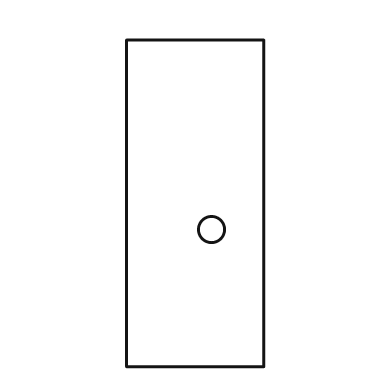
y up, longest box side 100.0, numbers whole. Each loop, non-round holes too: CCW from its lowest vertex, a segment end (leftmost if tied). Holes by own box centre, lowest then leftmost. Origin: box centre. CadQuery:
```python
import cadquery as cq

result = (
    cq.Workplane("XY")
    .moveTo(-21.0, -50.0)
    .lineTo(21.0, -50.0)
    .lineTo(21.0, 50.0)
    .lineTo(-21.0, 50.0)
    .close()
    .moveTo(5.0, -8.0)
    .circle(4.0)
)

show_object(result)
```